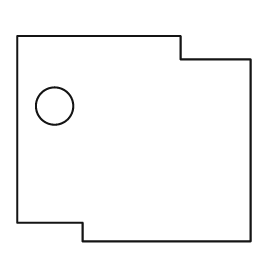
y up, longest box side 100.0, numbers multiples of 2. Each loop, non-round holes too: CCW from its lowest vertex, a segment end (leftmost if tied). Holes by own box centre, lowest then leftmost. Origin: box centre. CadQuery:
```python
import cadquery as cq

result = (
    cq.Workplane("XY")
    .moveTo(-22.0, -44.0)
    .lineTo(50.0, -44.0)
    .lineTo(50.0, 34.0)
    .lineTo(20.0, 34.0)
    .lineTo(20.0, 44.0)
    .lineTo(-50.0, 44.0)
    .lineTo(-50.0, -36.0)
    .lineTo(-22.0, -36.0)
    .close()
    .moveTo(-34.0, 14.0)
    .circle(8.0)
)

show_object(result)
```